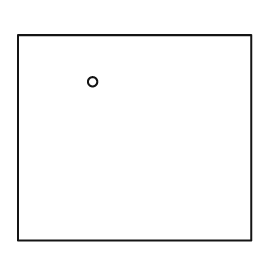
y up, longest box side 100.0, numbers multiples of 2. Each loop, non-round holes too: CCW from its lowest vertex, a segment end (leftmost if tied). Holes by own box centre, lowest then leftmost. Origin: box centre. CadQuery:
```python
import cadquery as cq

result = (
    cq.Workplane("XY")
    .moveTo(-50.0, -44.0)
    .lineTo(50.0, -44.0)
    .lineTo(50.0, 44.0)
    .lineTo(-50.0, 44.0)
    .close()
    .moveTo(-18.0, 24.0)
    .circle(2.0)
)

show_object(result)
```